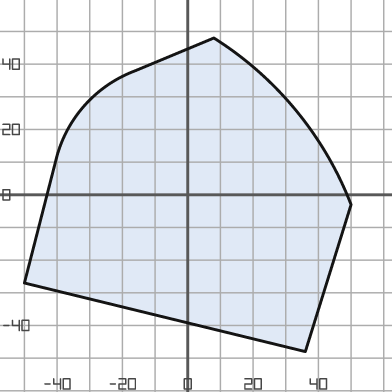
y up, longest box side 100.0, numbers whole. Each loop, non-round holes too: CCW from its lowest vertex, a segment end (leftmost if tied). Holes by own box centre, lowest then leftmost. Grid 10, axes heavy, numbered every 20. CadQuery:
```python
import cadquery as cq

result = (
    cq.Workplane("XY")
    .moveTo(36.0, -48.0)
    .lineTo(50.0, -3.0)
    .threePointArc((33.0, 26.0), (8.0, 48.0))
    .lineTo(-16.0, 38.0)
    .threePointArc((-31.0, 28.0), (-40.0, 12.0))
    .lineTo(-50.0, -27.0)
    .close()
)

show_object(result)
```